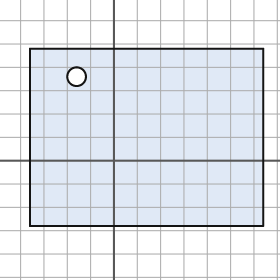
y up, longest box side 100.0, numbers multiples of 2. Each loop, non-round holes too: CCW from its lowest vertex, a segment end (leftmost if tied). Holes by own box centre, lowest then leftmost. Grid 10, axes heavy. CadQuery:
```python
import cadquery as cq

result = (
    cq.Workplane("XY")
    .moveTo(-36.0, -28.0)
    .lineTo(64.0, -28.0)
    .lineTo(64.0, 48.0)
    .lineTo(-36.0, 48.0)
    .close()
    .moveTo(-16.0, 36.0)
    .circle(4.0)
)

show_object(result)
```